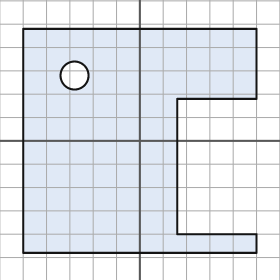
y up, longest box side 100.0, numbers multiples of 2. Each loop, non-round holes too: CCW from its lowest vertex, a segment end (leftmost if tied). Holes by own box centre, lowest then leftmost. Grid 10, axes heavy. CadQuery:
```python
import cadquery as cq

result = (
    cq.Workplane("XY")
    .moveTo(-50.0, -48.0)
    .lineTo(50.0, -48.0)
    .lineTo(50.0, -40.0)
    .lineTo(16.0, -40.0)
    .lineTo(16.0, 18.0)
    .lineTo(50.0, 18.0)
    .lineTo(50.0, 48.0)
    .lineTo(-50.0, 48.0)
    .close()
    .moveTo(-28.0, 28.0)
    .circle(6.0)
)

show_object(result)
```